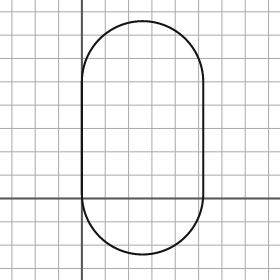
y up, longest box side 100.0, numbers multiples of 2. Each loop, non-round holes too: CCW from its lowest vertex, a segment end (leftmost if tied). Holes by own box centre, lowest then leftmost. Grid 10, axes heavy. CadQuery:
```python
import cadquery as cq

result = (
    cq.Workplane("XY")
    .moveTo(0.0, 2.0)
    .threePointArc((26.0, -24.0), (52.0, 2.0))
    .lineTo(52.0, 50.0)
    .threePointArc((26.0, 76.0), (0.0, 50.0))
    .close()
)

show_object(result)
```